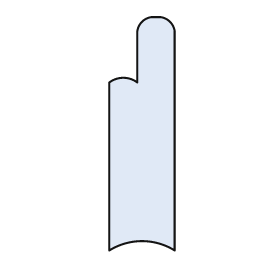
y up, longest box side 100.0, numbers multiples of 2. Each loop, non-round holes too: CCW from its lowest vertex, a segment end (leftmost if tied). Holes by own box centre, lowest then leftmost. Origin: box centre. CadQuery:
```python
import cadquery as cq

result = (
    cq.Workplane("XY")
    .moveTo(-14.0, -50.0)
    .threePointArc((0.0, -46.0), (14.0, -50.0))
    .lineTo(14.0, 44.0)
    .threePointArc((12.0, 48.0), (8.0, 50.0))
    .lineTo(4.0, 50.0)
    .threePointArc((0.0, 48.0), (-2.0, 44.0))
    .lineTo(-2.0, 22.0)
    .threePointArc((-8.0, 24.0), (-14.0, 22.0))
    .close()
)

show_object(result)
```